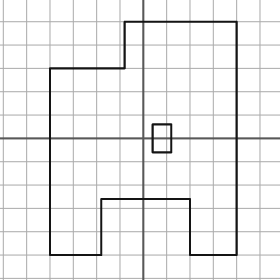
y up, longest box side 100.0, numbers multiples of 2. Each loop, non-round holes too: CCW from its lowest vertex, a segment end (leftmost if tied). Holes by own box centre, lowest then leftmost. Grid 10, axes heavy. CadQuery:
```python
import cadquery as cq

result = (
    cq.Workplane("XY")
    .moveTo(-40.0, -50.0)
    .lineTo(-18.0, -50.0)
    .lineTo(-18.0, -26.0)
    .lineTo(20.0, -26.0)
    .lineTo(20.0, -50.0)
    .lineTo(40.0, -50.0)
    .lineTo(40.0, 50.0)
    .lineTo(-8.0, 50.0)
    .lineTo(-8.0, 30.0)
    .lineTo(-40.0, 30.0)
    .close()
    .moveTo(4.0, -6.0)
    .lineTo(12.0, -6.0)
    .lineTo(12.0, 6.0)
    .lineTo(4.0, 6.0)
    .close()
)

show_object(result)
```